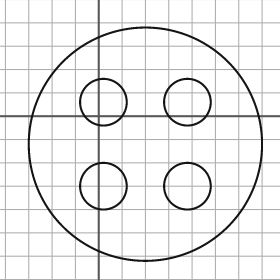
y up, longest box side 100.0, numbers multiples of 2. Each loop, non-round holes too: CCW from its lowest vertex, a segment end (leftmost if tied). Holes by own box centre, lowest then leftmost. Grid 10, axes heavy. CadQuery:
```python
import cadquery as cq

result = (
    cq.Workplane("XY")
    .moveTo(20.0, -12.0)
    .circle(50.0)
    .moveTo(2.0, -30.0)
    .circle(10.0)
    .moveTo(38.0, -30.0)
    .circle(10.0)
    .moveTo(2.0, 6.0)
    .circle(10.0)
    .moveTo(38.0, 6.0)
    .circle(10.0)
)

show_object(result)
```